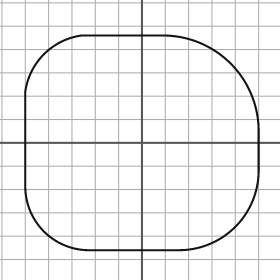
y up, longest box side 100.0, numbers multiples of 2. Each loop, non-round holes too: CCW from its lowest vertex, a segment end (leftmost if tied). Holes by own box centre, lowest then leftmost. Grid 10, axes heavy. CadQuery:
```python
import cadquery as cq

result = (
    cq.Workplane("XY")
    .moveTo(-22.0, -46.0)
    .lineTo(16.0, -46.0)
    .threePointArc((40.0, -36.0), (50.0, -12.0))
    .lineTo(50.0, 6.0)
    .threePointArc((38.0, 34.0), (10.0, 46.0))
    .lineTo(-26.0, 46.0)
    .threePointArc((-42.0, 38.0), (-50.0, 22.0))
    .lineTo(-50.0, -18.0)
    .threePointArc((-42.0, -38.0), (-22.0, -46.0))
    .close()
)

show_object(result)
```